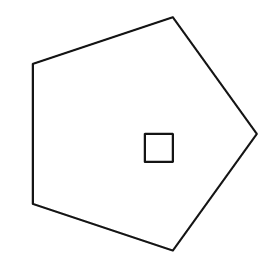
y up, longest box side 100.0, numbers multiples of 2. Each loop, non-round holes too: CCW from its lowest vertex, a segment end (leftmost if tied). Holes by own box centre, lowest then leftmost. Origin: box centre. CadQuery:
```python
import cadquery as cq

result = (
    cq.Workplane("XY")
    .moveTo(12.0, -50.0)
    .lineTo(48.0, 0.0)
    .lineTo(12.0, 50.0)
    .lineTo(-48.0, 30.0)
    .lineTo(-48.0, -30.0)
    .close()
    .moveTo(0.0, -12.0)
    .lineTo(12.0, -12.0)
    .lineTo(12.0, 0.0)
    .lineTo(0.0, 0.0)
    .close()
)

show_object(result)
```